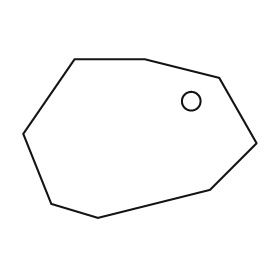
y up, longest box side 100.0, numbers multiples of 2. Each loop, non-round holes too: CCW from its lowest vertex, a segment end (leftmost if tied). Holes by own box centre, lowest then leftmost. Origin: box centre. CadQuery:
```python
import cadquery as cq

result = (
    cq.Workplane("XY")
    .moveTo(-18.0, -34.0)
    .lineTo(30.0, -22.0)
    .lineTo(50.0, -2.0)
    .lineTo(34.0, 26.0)
    .lineTo(2.0, 34.0)
    .lineTo(-28.0, 34.0)
    .lineTo(-50.0, 2.0)
    .lineTo(-38.0, -28.0)
    .close()
    .moveTo(22.0, 16.0)
    .circle(4.0)
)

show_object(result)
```